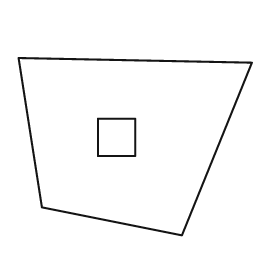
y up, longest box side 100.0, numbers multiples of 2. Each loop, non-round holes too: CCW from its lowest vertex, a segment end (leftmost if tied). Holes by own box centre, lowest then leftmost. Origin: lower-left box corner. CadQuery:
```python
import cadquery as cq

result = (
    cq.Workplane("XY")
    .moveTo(70.0, 0.0)
    .lineTo(100.0, 74.0)
    .lineTo(0.0, 76.0)
    .lineTo(10.0, 12.0)
    .close()
    .moveTo(34.0, 34.0)
    .lineTo(50.0, 34.0)
    .lineTo(50.0, 50.0)
    .lineTo(34.0, 50.0)
    .close()
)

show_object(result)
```